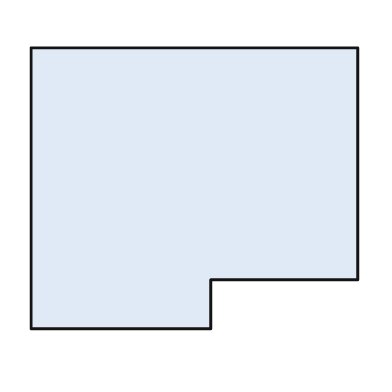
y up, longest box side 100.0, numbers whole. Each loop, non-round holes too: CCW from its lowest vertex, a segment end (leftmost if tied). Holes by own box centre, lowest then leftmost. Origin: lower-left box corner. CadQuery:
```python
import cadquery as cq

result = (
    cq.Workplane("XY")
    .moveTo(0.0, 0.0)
    .lineTo(55.0, 0.0)
    .lineTo(55.0, 15.0)
    .lineTo(100.0, 15.0)
    .lineTo(100.0, 86.0)
    .lineTo(0.0, 86.0)
    .close()
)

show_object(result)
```